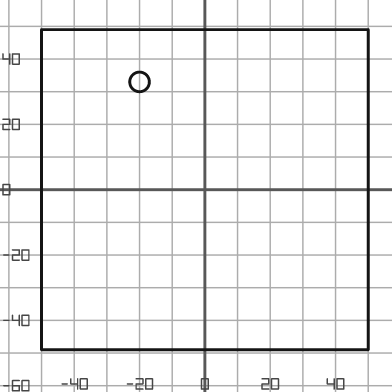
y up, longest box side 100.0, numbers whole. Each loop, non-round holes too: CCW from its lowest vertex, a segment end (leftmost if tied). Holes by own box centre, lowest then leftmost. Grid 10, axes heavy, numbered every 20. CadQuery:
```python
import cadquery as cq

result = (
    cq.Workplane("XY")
    .moveTo(-50.0, -49.0)
    .lineTo(50.0, -49.0)
    .lineTo(50.0, 49.0)
    .lineTo(-50.0, 49.0)
    .close()
    .moveTo(-20.0, 33.0)
    .circle(3.0)
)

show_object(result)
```